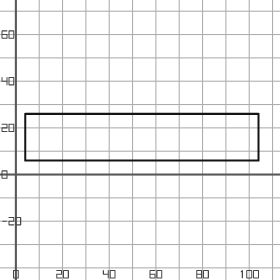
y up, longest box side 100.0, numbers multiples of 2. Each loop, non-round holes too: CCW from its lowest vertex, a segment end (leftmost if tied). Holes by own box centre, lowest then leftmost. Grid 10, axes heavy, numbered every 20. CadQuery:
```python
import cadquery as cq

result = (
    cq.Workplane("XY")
    .moveTo(4.0, 6.0)
    .lineTo(104.0, 6.0)
    .lineTo(104.0, 26.0)
    .lineTo(4.0, 26.0)
    .close()
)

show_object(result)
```